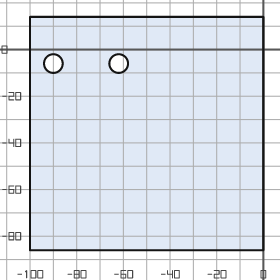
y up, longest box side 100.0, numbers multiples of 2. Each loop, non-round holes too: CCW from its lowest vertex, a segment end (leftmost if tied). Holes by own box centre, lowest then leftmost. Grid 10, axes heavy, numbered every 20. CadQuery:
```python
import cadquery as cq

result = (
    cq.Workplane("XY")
    .moveTo(-100.0, -86.0)
    .lineTo(0.0, -86.0)
    .lineTo(0.0, 14.0)
    .lineTo(-100.0, 14.0)
    .close()
    .moveTo(-90.0, -6.0)
    .circle(4.0)
    .moveTo(-62.0, -6.0)
    .circle(4.0)
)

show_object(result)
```